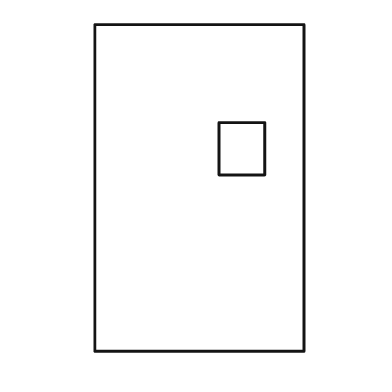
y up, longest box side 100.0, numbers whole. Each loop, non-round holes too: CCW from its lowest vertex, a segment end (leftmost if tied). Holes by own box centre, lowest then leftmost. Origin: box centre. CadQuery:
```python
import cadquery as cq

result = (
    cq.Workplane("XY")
    .moveTo(-32.0, -50.0)
    .lineTo(32.0, -50.0)
    .lineTo(32.0, 50.0)
    .lineTo(-32.0, 50.0)
    .close()
    .moveTo(6.0, 4.0)
    .lineTo(20.0, 4.0)
    .lineTo(20.0, 20.0)
    .lineTo(6.0, 20.0)
    .close()
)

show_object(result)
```